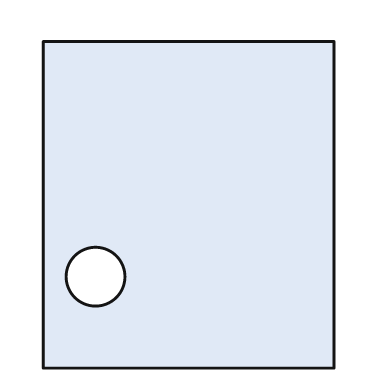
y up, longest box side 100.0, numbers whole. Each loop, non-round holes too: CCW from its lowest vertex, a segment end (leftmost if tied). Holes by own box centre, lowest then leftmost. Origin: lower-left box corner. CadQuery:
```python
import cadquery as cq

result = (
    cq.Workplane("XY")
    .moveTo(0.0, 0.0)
    .lineTo(89.0, 0.0)
    .lineTo(89.0, 100.0)
    .lineTo(0.0, 100.0)
    .close()
    .moveTo(16.0, 28.0)
    .circle(9.0)
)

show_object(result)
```